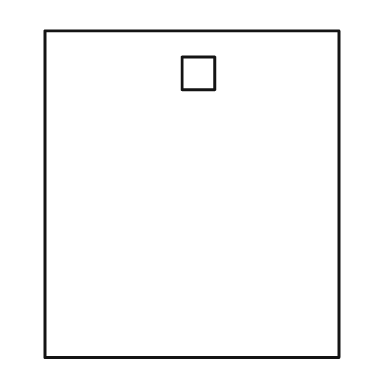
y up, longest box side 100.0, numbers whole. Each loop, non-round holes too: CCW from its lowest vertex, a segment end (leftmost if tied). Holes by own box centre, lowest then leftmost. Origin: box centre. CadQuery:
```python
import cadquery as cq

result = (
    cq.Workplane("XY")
    .moveTo(-45.0, -50.0)
    .lineTo(45.0, -50.0)
    .lineTo(45.0, 50.0)
    .lineTo(-45.0, 50.0)
    .close()
    .moveTo(-3.0, 32.0)
    .lineTo(7.0, 32.0)
    .lineTo(7.0, 42.0)
    .lineTo(-3.0, 42.0)
    .close()
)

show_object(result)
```